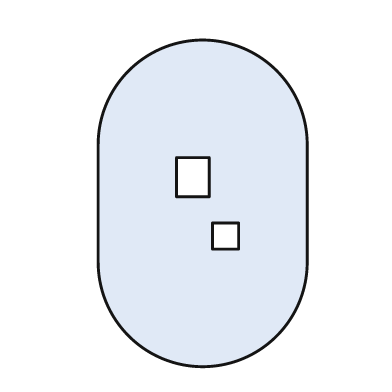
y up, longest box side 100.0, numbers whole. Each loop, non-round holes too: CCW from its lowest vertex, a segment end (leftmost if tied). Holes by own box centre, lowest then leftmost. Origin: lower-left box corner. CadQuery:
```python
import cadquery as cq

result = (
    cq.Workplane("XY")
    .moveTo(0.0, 32.0)
    .threePointArc((32.0, 0.0), (64.0, 32.0))
    .lineTo(64.0, 68.0)
    .threePointArc((32.0, 100.0), (0.0, 68.0))
    .close()
    .moveTo(35.0, 36.0)
    .lineTo(43.0, 36.0)
    .lineTo(43.0, 44.0)
    .lineTo(35.0, 44.0)
    .close()
    .moveTo(24.0, 52.0)
    .lineTo(34.0, 52.0)
    .lineTo(34.0, 64.0)
    .lineTo(24.0, 64.0)
    .close()
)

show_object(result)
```